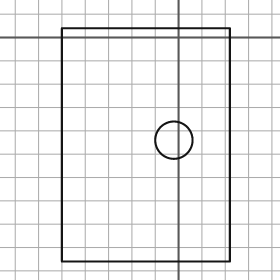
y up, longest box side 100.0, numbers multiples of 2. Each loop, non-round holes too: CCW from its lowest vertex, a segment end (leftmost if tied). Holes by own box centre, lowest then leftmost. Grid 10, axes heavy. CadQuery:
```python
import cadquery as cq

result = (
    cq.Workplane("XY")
    .moveTo(-50.0, -96.0)
    .lineTo(22.0, -96.0)
    .lineTo(22.0, 4.0)
    .lineTo(-50.0, 4.0)
    .close()
    .moveTo(-2.0, -44.0)
    .circle(8.0)
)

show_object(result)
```